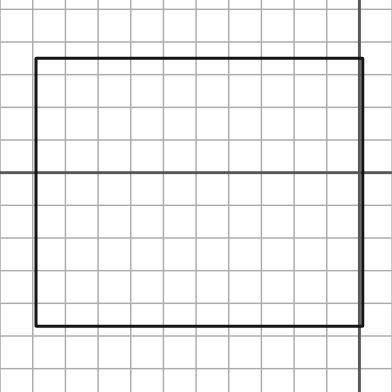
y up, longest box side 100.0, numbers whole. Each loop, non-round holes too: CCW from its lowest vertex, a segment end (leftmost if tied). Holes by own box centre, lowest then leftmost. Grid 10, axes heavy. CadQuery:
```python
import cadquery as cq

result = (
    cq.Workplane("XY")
    .moveTo(-99.0, -47.0)
    .lineTo(1.0, -47.0)
    .lineTo(1.0, 35.0)
    .lineTo(-99.0, 35.0)
    .close()
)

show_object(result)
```